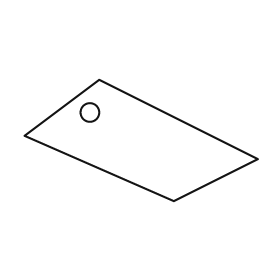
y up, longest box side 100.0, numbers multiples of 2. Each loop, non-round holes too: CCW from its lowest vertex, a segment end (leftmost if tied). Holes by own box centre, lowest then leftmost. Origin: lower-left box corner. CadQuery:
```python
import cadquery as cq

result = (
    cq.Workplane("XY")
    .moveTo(64.0, 0.0)
    .lineTo(100.0, 18.0)
    .lineTo(32.0, 52.0)
    .lineTo(0.0, 28.0)
    .close()
    .moveTo(28.0, 38.0)
    .circle(4.0)
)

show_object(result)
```